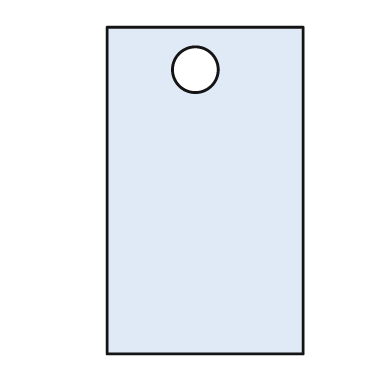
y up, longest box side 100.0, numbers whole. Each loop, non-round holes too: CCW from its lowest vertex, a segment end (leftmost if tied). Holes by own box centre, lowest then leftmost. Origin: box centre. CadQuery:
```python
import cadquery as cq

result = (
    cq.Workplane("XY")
    .moveTo(-30.0, -50.0)
    .lineTo(30.0, -50.0)
    .lineTo(30.0, 50.0)
    .lineTo(-30.0, 50.0)
    .close()
    .moveTo(-3.0, 37.0)
    .circle(7.0)
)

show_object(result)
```